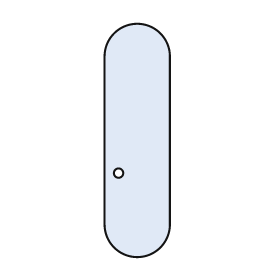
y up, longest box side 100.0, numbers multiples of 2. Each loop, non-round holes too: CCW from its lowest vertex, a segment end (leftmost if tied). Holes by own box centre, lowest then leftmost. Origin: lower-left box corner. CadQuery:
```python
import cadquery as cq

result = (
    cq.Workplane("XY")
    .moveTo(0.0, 14.0)
    .threePointArc((14.0, 0.0), (28.0, 14.0))
    .lineTo(28.0, 86.0)
    .threePointArc((14.0, 100.0), (0.0, 86.0))
    .close()
    .moveTo(6.0, 36.0)
    .circle(2.0)
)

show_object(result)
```